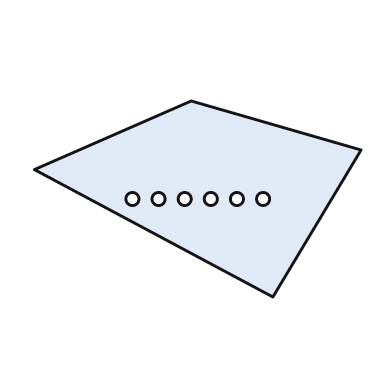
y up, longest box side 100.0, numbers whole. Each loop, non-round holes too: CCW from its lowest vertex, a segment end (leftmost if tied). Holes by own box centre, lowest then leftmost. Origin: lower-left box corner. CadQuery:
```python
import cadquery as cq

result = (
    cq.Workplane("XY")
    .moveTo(73.0, 0.0)
    .lineTo(100.0, 45.0)
    .lineTo(48.0, 60.0)
    .lineTo(0.0, 39.0)
    .close()
    .moveTo(30.0, 30.0)
    .circle(2.0)
    .moveTo(38.0, 30.0)
    .circle(2.0)
    .moveTo(46.0, 30.0)
    .circle(2.0)
    .moveTo(54.0, 30.0)
    .circle(2.0)
    .moveTo(62.0, 30.0)
    .circle(2.0)
    .moveTo(70.0, 30.0)
    .circle(2.0)
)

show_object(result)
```